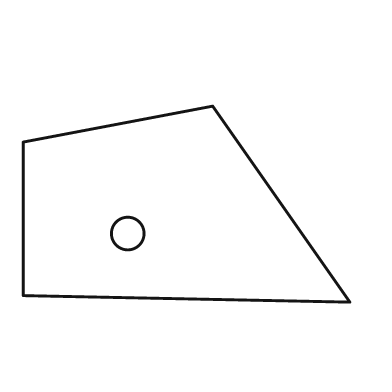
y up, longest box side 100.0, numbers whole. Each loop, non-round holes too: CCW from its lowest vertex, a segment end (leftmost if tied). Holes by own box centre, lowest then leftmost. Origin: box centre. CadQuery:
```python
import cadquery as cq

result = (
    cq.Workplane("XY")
    .moveTo(50.0, -30.0)
    .lineTo(8.0, 30.0)
    .lineTo(-50.0, 19.0)
    .lineTo(-50.0, -28.0)
    .close()
    .moveTo(-18.0, -9.0)
    .circle(5.0)
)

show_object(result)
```